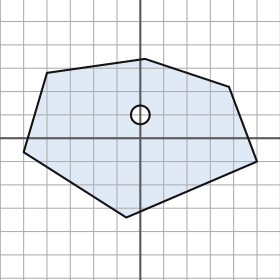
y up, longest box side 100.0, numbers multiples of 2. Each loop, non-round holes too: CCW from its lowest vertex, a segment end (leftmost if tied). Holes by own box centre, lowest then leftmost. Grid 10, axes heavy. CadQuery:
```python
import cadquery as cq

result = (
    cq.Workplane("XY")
    .moveTo(-6.0, -34.0)
    .lineTo(50.0, -10.0)
    .lineTo(38.0, 22.0)
    .lineTo(2.0, 34.0)
    .lineTo(-40.0, 28.0)
    .lineTo(-50.0, -6.0)
    .close()
    .moveTo(0.0, 10.0)
    .circle(4.0)
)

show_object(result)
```